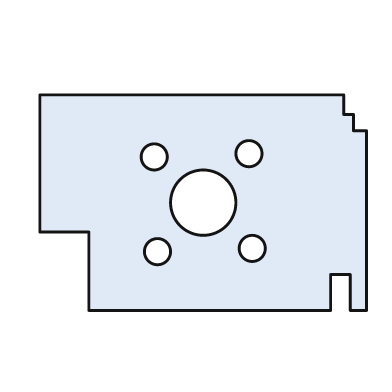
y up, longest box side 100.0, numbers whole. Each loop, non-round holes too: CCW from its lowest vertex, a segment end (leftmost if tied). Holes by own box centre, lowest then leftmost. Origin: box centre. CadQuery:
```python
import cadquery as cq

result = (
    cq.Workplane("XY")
    .moveTo(-35.0, -33.0)
    .lineTo(39.0, -33.0)
    .lineTo(39.0, -22.0)
    .lineTo(45.0, -22.0)
    .lineTo(45.0, -33.0)
    .lineTo(50.0, -33.0)
    .lineTo(50.0, 22.0)
    .lineTo(46.0, 22.0)
    .lineTo(46.0, 27.0)
    .lineTo(43.0, 27.0)
    .lineTo(43.0, 33.0)
    .lineTo(-50.0, 33.0)
    .lineTo(-50.0, -9.0)
    .lineTo(-35.0, -9.0)
    .close()
    .moveTo(-14.0, -15.0)
    .circle(4.0)
    .moveTo(15.0, -14.0)
    .circle(4.0)
    .moveTo(0.0, 0.0)
    .circle(10.0)
    .moveTo(-15.0, 14.0)
    .circle(4.0)
    .moveTo(14.0, 15.0)
    .circle(4.0)
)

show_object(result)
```